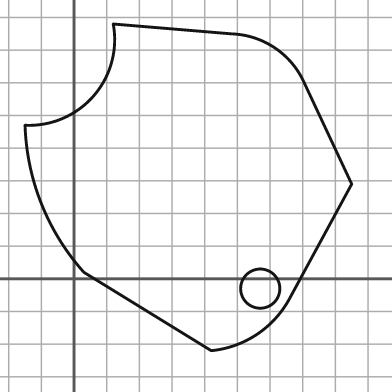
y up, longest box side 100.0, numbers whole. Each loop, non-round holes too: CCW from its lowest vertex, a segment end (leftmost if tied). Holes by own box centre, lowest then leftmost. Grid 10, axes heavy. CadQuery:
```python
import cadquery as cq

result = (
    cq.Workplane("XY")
    .moveTo(42.0, -22.0)
    .threePointArc((56.0, -17.0), (66.0, -6.0))
    .lineTo(85.0, 29.0)
    .lineTo(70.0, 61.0)
    .threePointArc((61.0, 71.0), (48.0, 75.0))
    .lineTo(12.0, 78.0)
    .threePointArc((6.0, 56.0), (-15.0, 47.0))
    .threePointArc((-10.0, 23.0), (3.0, 2.0))
    .close()
    .moveTo(57.0, -3.0)
    .circle(6.0)
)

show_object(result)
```